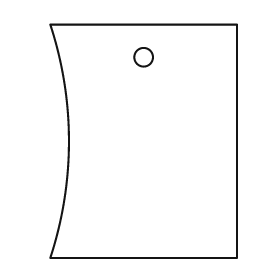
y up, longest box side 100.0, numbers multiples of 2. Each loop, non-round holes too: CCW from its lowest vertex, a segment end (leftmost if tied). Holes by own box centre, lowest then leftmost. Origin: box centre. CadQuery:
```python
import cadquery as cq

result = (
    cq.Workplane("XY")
    .moveTo(-40.0, -50.0)
    .lineTo(40.0, -50.0)
    .lineTo(40.0, 50.0)
    .lineTo(-40.0, 50.0)
    .threePointArc((-32.0, 0.0), (-40.0, -50.0))
    .close()
    .moveTo(0.0, 36.0)
    .circle(4.0)
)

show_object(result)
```